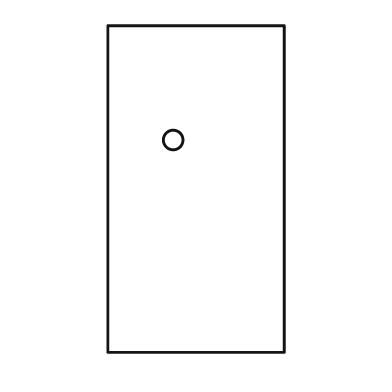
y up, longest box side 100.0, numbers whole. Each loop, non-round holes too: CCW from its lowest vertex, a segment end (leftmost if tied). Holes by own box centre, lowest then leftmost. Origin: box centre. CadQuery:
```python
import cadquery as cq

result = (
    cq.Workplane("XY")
    .moveTo(-27.0, -50.0)
    .lineTo(27.0, -50.0)
    .lineTo(27.0, 50.0)
    .lineTo(-27.0, 50.0)
    .close()
    .moveTo(-7.0, 15.0)
    .circle(3.0)
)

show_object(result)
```